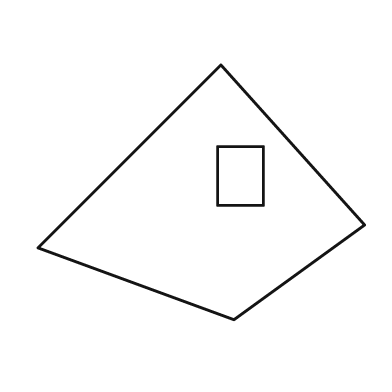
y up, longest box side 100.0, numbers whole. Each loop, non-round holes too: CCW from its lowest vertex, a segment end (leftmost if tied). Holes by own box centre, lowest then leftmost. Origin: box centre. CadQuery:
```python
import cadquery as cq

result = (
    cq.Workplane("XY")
    .moveTo(10.0, -39.0)
    .lineTo(50.0, -10.0)
    .lineTo(6.0, 39.0)
    .lineTo(-50.0, -17.0)
    .close()
    .moveTo(5.0, -4.0)
    .lineTo(19.0, -4.0)
    .lineTo(19.0, 14.0)
    .lineTo(5.0, 14.0)
    .close()
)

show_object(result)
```